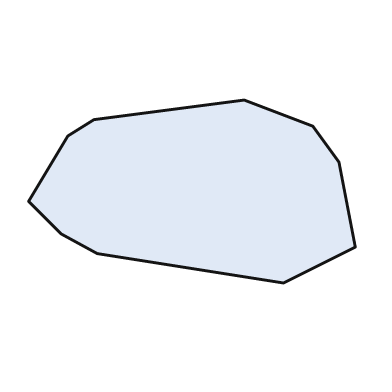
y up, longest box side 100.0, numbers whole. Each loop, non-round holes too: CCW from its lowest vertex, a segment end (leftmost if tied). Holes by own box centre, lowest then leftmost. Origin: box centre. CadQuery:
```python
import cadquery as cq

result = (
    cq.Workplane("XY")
    .moveTo(28.0, -28.0)
    .lineTo(50.0, -17.0)
    .lineTo(45.0, 9.0)
    .lineTo(37.0, 20.0)
    .lineTo(16.0, 28.0)
    .lineTo(-30.0, 22.0)
    .lineTo(-38.0, 17.0)
    .lineTo(-50.0, -3.0)
    .lineTo(-40.0, -13.0)
    .lineTo(-29.0, -19.0)
    .close()
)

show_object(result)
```